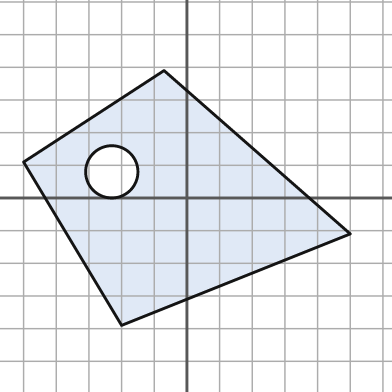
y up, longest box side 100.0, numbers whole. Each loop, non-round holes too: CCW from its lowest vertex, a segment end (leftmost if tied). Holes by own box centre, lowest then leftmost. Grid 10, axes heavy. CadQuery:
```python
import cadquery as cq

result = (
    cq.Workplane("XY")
    .moveTo(-20.0, -39.0)
    .lineTo(50.0, -11.0)
    .lineTo(-7.0, 39.0)
    .lineTo(-50.0, 11.0)
    .close()
    .moveTo(-23.0, 8.0)
    .circle(8.0)
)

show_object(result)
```